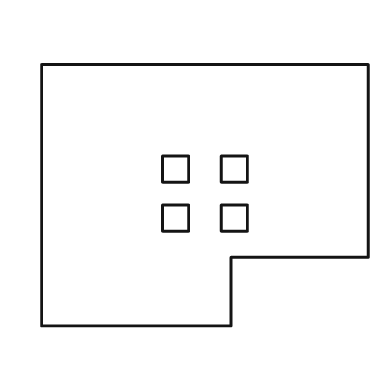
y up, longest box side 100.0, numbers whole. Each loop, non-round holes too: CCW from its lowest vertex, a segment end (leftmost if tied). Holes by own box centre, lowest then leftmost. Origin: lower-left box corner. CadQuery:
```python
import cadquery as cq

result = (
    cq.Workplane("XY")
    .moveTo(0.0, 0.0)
    .lineTo(58.0, 0.0)
    .lineTo(58.0, 21.0)
    .lineTo(100.0, 21.0)
    .lineTo(100.0, 80.0)
    .lineTo(0.0, 80.0)
    .close()
    .moveTo(37.0, 29.0)
    .lineTo(45.0, 29.0)
    .lineTo(45.0, 37.0)
    .lineTo(37.0, 37.0)
    .close()
    .moveTo(55.0, 29.0)
    .lineTo(63.0, 29.0)
    .lineTo(63.0, 37.0)
    .lineTo(55.0, 37.0)
    .close()
    .moveTo(37.0, 44.0)
    .lineTo(45.0, 44.0)
    .lineTo(45.0, 52.0)
    .lineTo(37.0, 52.0)
    .close()
    .moveTo(55.0, 44.0)
    .lineTo(63.0, 44.0)
    .lineTo(63.0, 52.0)
    .lineTo(55.0, 52.0)
    .close()
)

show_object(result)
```